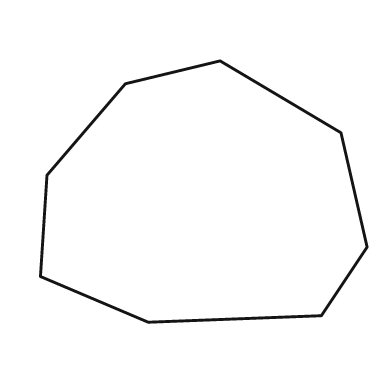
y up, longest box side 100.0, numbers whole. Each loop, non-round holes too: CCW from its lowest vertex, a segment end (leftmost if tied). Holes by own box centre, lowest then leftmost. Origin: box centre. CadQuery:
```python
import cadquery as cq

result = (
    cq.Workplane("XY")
    .moveTo(-17.0, -40.0)
    .lineTo(36.0, -38.0)
    .lineTo(50.0, -17.0)
    .lineTo(42.0, 18.0)
    .lineTo(5.0, 40.0)
    .lineTo(-24.0, 33.0)
    .lineTo(-48.0, 5.0)
    .lineTo(-50.0, -26.0)
    .close()
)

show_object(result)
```